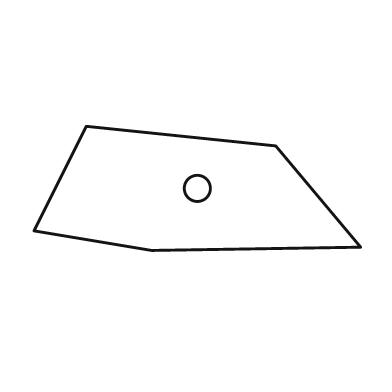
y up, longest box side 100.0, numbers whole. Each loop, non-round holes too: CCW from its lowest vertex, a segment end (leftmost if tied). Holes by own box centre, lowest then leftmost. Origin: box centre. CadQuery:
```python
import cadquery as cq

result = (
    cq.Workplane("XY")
    .moveTo(-14.0, -19.0)
    .lineTo(50.0, -18.0)
    .lineTo(24.0, 13.0)
    .lineTo(-34.0, 19.0)
    .lineTo(-50.0, -13.0)
    .close()
    .moveTo(0.0, 0.0)
    .circle(4.0)
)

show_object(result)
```